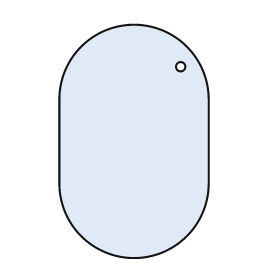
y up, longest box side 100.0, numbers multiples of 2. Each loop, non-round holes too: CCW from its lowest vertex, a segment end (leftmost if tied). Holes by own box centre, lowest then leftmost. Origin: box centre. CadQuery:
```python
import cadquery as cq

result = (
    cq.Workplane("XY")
    .moveTo(-32.0, -18.0)
    .threePointArc((0.0, -50.0), (32.0, -18.0))
    .lineTo(32.0, 18.0)
    .threePointArc((0.0, 50.0), (-32.0, 18.0))
    .close()
    .moveTo(20.0, 32.0)
    .circle(2.0)
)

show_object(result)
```